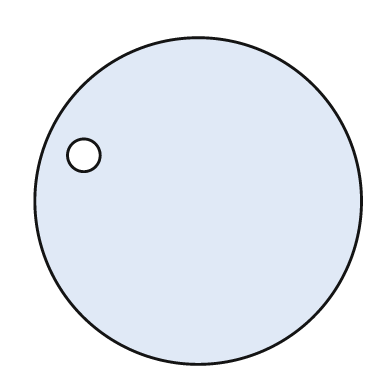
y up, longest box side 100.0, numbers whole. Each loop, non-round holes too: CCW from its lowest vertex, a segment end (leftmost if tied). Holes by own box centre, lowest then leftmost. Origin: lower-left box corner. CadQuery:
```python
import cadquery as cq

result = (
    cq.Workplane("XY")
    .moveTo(50.0, 50.0)
    .circle(50.0)
    .moveTo(15.0, 64.0)
    .circle(5.0)
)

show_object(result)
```